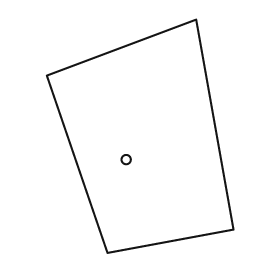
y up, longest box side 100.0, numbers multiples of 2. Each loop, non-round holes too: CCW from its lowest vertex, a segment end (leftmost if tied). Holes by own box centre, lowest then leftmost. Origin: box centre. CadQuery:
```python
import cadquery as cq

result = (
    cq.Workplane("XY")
    .moveTo(-14.0, -50.0)
    .lineTo(40.0, -40.0)
    .lineTo(24.0, 50.0)
    .lineTo(-40.0, 26.0)
    .close()
    .moveTo(-6.0, -10.0)
    .circle(2.0)
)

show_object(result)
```